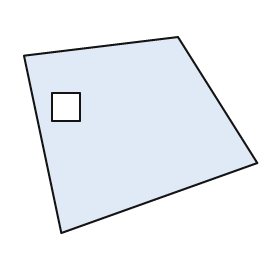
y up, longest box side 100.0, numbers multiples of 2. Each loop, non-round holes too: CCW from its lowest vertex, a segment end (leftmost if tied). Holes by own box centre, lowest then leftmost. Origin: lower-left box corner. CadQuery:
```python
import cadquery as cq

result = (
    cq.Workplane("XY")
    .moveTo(16.0, 0.0)
    .lineTo(100.0, 30.0)
    .lineTo(66.0, 84.0)
    .lineTo(0.0, 76.0)
    .close()
    .moveTo(12.0, 48.0)
    .lineTo(24.0, 48.0)
    .lineTo(24.0, 60.0)
    .lineTo(12.0, 60.0)
    .close()
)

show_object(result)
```